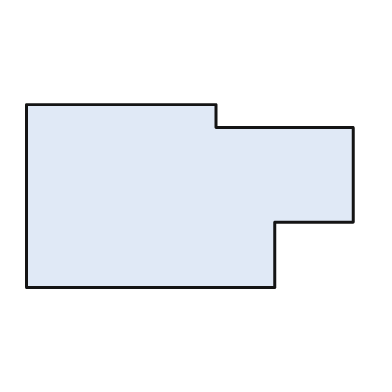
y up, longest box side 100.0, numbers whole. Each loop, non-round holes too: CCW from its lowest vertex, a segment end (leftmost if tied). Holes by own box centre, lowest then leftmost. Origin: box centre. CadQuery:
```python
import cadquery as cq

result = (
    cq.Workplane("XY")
    .moveTo(-50.0, -28.0)
    .lineTo(26.0, -28.0)
    .lineTo(26.0, -8.0)
    .lineTo(50.0, -8.0)
    .lineTo(50.0, 21.0)
    .lineTo(8.0, 21.0)
    .lineTo(8.0, 28.0)
    .lineTo(-50.0, 28.0)
    .close()
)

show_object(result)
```